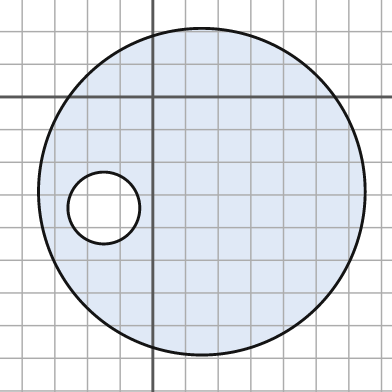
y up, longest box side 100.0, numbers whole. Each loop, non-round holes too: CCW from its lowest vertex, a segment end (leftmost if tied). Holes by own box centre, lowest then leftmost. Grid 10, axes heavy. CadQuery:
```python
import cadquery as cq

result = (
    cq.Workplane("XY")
    .moveTo(15.0, -29.0)
    .circle(50.0)
    .moveTo(-15.0, -34.0)
    .circle(11.0)
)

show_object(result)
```